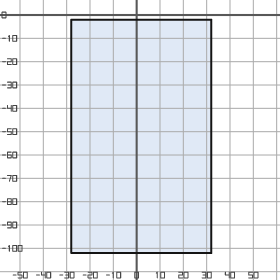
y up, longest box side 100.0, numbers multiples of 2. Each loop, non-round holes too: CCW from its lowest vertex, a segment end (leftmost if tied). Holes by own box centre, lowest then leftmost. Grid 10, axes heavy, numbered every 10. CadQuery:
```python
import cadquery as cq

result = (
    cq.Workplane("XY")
    .moveTo(-28.0, -102.0)
    .lineTo(32.0, -102.0)
    .lineTo(32.0, -2.0)
    .lineTo(-28.0, -2.0)
    .close()
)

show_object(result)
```